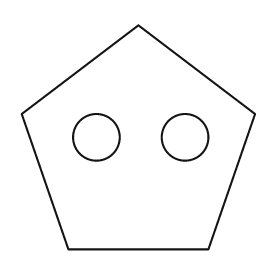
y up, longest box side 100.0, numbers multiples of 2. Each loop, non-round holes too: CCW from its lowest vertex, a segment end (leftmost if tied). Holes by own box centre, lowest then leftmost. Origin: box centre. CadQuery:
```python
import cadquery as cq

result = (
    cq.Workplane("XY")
    .moveTo(-30.0, -48.0)
    .lineTo(30.0, -48.0)
    .lineTo(50.0, 10.0)
    .lineTo(0.0, 48.0)
    .lineTo(-50.0, 10.0)
    .close()
    .moveTo(-18.0, 0.0)
    .circle(10.0)
    .moveTo(20.0, 0.0)
    .circle(10.0)
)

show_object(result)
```